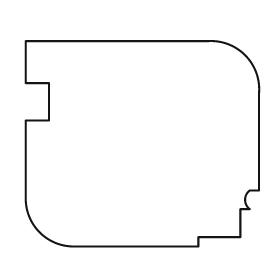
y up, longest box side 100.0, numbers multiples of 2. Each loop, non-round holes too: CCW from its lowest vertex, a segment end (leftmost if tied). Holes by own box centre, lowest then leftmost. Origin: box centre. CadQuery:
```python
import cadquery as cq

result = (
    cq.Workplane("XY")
    .moveTo(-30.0, -44.0)
    .lineTo(24.0, -44.0)
    .lineTo(24.0, -40.0)
    .lineTo(42.0, -40.0)
    .lineTo(42.0, -28.0)
    .lineTo(46.0, -28.0)
    .threePointArc((44.0, -24.0), (46.0, -20.0))
    .lineTo(50.0, -20.0)
    .lineTo(50.0, 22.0)
    .threePointArc((44.0, 38.0), (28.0, 44.0))
    .lineTo(-50.0, 44.0)
    .lineTo(-50.0, 26.0)
    .lineTo(-40.0, 26.0)
    .lineTo(-40.0, 10.0)
    .lineTo(-50.0, 10.0)
    .lineTo(-50.0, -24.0)
    .threePointArc((-44.0, -38.0), (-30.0, -44.0))
    .close()
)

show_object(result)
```